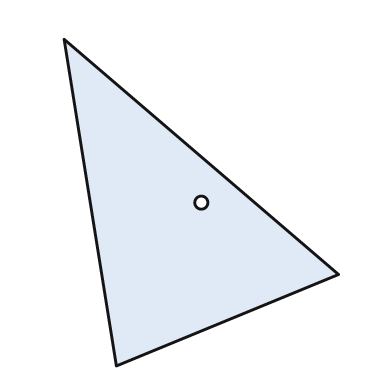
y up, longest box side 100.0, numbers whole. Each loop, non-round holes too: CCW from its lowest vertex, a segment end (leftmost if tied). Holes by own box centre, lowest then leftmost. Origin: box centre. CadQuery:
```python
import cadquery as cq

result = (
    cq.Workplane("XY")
    .moveTo(-26.0, -50.0)
    .lineTo(42.0, -22.0)
    .lineTo(-42.0, 50.0)
    .close()
    .moveTo(0.0, 0.0)
    .circle(2.0)
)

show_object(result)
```